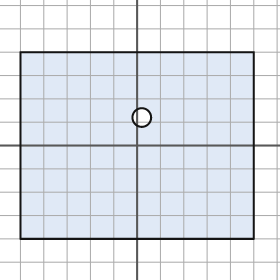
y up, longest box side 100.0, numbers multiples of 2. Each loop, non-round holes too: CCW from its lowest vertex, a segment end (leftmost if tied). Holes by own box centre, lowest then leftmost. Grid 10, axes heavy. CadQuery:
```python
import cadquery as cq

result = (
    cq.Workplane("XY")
    .moveTo(-50.0, -40.0)
    .lineTo(50.0, -40.0)
    .lineTo(50.0, 40.0)
    .lineTo(-50.0, 40.0)
    .close()
    .moveTo(2.0, 12.0)
    .circle(4.0)
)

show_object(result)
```